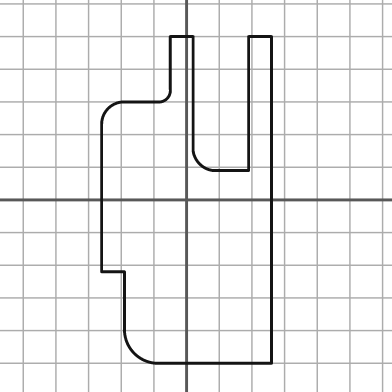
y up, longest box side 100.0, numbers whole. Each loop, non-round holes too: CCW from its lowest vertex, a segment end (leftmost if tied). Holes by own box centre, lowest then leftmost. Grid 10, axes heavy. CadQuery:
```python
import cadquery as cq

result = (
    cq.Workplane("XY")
    .moveTo(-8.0, -50.0)
    .lineTo(26.0, -50.0)
    .lineTo(26.0, 50.0)
    .lineTo(19.0, 50.0)
    .lineTo(19.0, 9.0)
    .lineTo(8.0, 9.0)
    .threePointArc((4.0, 11.0), (2.0, 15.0))
    .lineTo(2.0, 50.0)
    .lineTo(-5.0, 50.0)
    .lineTo(-5.0, 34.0)
    .threePointArc((-6.0, 31.0), (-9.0, 30.0))
    .lineTo(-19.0, 30.0)
    .threePointArc((-24.0, 28.0), (-26.0, 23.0))
    .lineTo(-26.0, -22.0)
    .lineTo(-19.0, -22.0)
    .lineTo(-19.0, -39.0)
    .threePointArc((-16.0, -47.0), (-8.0, -50.0))
    .close()
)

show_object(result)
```